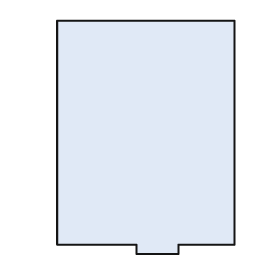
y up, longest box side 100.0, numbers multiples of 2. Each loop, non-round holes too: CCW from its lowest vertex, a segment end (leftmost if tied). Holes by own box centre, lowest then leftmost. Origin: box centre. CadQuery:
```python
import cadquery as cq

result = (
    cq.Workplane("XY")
    .moveTo(-4.0, -50.0)
    .lineTo(14.0, -50.0)
    .lineTo(14.0, -46.0)
    .lineTo(38.0, -46.0)
    .lineTo(38.0, 50.0)
    .lineTo(-38.0, 50.0)
    .lineTo(-38.0, -46.0)
    .lineTo(-4.0, -46.0)
    .close()
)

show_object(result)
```